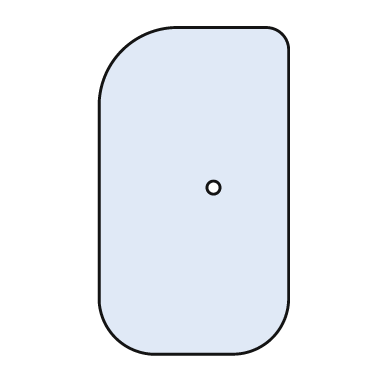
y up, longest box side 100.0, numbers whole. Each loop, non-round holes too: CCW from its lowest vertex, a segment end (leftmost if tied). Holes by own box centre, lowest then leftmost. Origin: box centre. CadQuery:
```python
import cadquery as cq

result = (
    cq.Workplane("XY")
    .moveTo(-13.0, -50.0)
    .lineTo(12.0, -50.0)
    .threePointArc((24.0, -45.0), (29.0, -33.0))
    .lineTo(29.0, 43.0)
    .threePointArc((27.0, 48.0), (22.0, 50.0))
    .lineTo(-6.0, 50.0)
    .threePointArc((-22.0, 43.0), (-29.0, 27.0))
    .lineTo(-29.0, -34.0)
    .threePointArc((-24.0, -45.0), (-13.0, -50.0))
    .close()
    .moveTo(6.0, 1.0)
    .circle(2.0)
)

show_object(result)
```